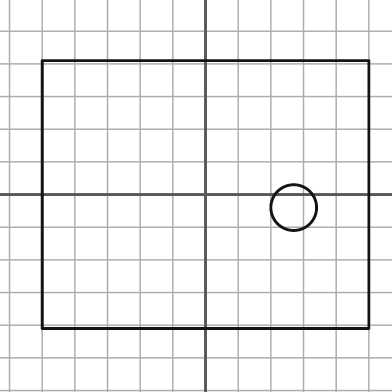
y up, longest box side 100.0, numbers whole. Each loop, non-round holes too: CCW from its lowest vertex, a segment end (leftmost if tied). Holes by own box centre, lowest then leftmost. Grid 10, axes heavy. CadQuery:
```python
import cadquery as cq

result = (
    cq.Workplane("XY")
    .moveTo(-50.0, -41.0)
    .lineTo(50.0, -41.0)
    .lineTo(50.0, 41.0)
    .lineTo(-50.0, 41.0)
    .close()
    .moveTo(27.0, -4.0)
    .circle(7.0)
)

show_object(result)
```